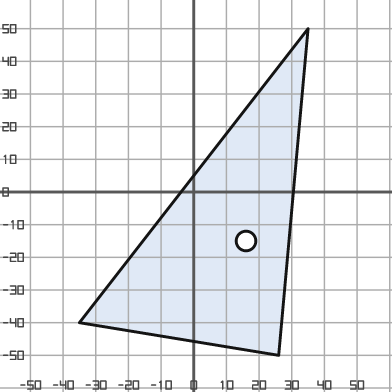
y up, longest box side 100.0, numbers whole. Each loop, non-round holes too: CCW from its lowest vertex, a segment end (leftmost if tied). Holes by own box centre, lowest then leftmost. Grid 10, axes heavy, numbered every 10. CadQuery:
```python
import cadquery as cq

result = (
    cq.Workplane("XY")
    .moveTo(26.0, -50.0)
    .lineTo(35.0, 50.0)
    .lineTo(-35.0, -40.0)
    .close()
    .moveTo(16.0, -15.0)
    .circle(3.0)
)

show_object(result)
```